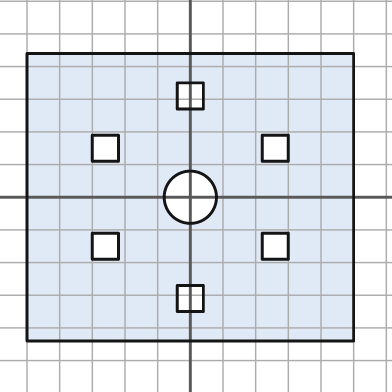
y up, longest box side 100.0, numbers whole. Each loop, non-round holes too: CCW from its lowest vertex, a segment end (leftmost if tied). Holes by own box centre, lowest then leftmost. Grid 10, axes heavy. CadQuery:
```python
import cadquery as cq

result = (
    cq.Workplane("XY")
    .moveTo(-50.0, -44.0)
    .lineTo(50.0, -44.0)
    .lineTo(50.0, 44.0)
    .lineTo(-50.0, 44.0)
    .close()
    .moveTo(-4.0, -35.0)
    .lineTo(4.0, -35.0)
    .lineTo(4.0, -27.0)
    .lineTo(-4.0, -27.0)
    .close()
    .moveTo(-30.0, -19.0)
    .lineTo(-22.0, -19.0)
    .lineTo(-22.0, -11.0)
    .lineTo(-30.0, -11.0)
    .close()
    .moveTo(22.0, -19.0)
    .lineTo(30.0, -19.0)
    .lineTo(30.0, -11.0)
    .lineTo(22.0, -11.0)
    .close()
    .moveTo(0.0, 0.0)
    .circle(8.0)
    .moveTo(-30.0, 11.0)
    .lineTo(-22.0, 11.0)
    .lineTo(-22.0, 19.0)
    .lineTo(-30.0, 19.0)
    .close()
    .moveTo(22.0, 11.0)
    .lineTo(30.0, 11.0)
    .lineTo(30.0, 19.0)
    .lineTo(22.0, 19.0)
    .close()
    .moveTo(-4.0, 27.0)
    .lineTo(4.0, 27.0)
    .lineTo(4.0, 35.0)
    .lineTo(-4.0, 35.0)
    .close()
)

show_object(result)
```